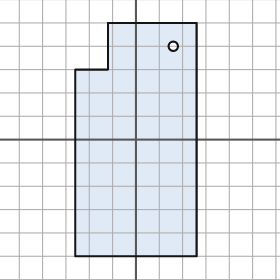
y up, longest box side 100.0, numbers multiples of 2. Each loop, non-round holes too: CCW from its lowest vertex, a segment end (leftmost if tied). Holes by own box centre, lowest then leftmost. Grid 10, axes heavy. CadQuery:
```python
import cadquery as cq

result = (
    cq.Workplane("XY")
    .moveTo(-26.0, -50.0)
    .lineTo(26.0, -50.0)
    .lineTo(26.0, 50.0)
    .lineTo(-12.0, 50.0)
    .lineTo(-12.0, 30.0)
    .lineTo(-26.0, 30.0)
    .close()
    .moveTo(16.0, 40.0)
    .circle(2.0)
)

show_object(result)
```